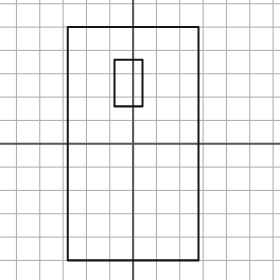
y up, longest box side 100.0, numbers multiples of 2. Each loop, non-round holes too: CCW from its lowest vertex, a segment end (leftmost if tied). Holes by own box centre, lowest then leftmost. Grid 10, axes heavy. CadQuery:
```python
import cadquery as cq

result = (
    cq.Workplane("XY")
    .moveTo(-28.0, -50.0)
    .lineTo(28.0, -50.0)
    .lineTo(28.0, 50.0)
    .lineTo(-28.0, 50.0)
    .close()
    .moveTo(-8.0, 16.0)
    .lineTo(4.0, 16.0)
    .lineTo(4.0, 36.0)
    .lineTo(-8.0, 36.0)
    .close()
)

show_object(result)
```